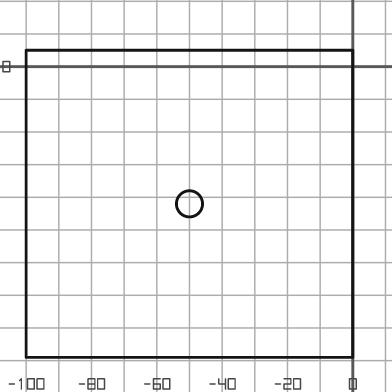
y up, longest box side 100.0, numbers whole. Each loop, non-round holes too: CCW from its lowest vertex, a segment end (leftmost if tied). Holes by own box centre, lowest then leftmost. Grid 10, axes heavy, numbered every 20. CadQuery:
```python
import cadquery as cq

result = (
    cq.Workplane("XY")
    .moveTo(-100.0, -89.0)
    .lineTo(0.0, -89.0)
    .lineTo(0.0, 5.0)
    .lineTo(-100.0, 5.0)
    .close()
    .moveTo(-50.0, -42.0)
    .circle(4.0)
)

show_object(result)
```